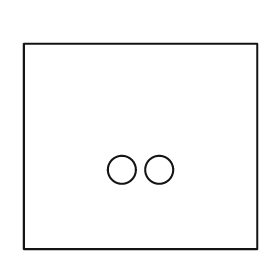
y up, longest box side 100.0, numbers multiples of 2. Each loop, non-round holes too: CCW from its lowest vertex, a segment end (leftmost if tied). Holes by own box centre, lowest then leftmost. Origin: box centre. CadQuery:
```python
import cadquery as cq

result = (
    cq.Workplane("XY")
    .moveTo(-50.0, -44.0)
    .lineTo(50.0, -44.0)
    .lineTo(50.0, 44.0)
    .lineTo(-50.0, 44.0)
    .close()
    .moveTo(-8.0, -10.0)
    .circle(6.0)
    .moveTo(8.0, -10.0)
    .circle(6.0)
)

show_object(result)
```